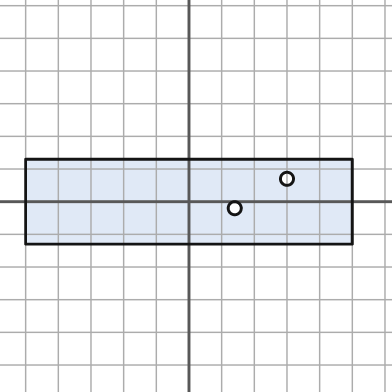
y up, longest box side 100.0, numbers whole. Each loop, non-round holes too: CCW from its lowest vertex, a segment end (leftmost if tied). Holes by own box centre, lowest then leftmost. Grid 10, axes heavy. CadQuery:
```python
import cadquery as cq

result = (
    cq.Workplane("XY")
    .moveTo(-50.0, -13.0)
    .lineTo(50.0, -13.0)
    .lineTo(50.0, 13.0)
    .lineTo(-50.0, 13.0)
    .close()
    .moveTo(14.0, -2.0)
    .circle(2.0)
    .moveTo(30.0, 7.0)
    .circle(2.0)
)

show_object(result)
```